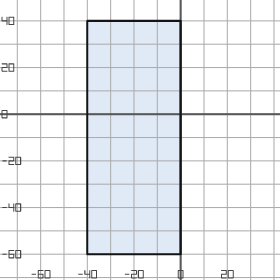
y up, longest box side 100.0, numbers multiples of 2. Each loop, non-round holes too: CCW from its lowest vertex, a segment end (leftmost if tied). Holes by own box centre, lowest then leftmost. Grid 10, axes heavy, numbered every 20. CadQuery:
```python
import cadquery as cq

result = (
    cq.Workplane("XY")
    .moveTo(-40.0, -60.0)
    .lineTo(0.0, -60.0)
    .lineTo(0.0, 40.0)
    .lineTo(-40.0, 40.0)
    .close()
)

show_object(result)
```